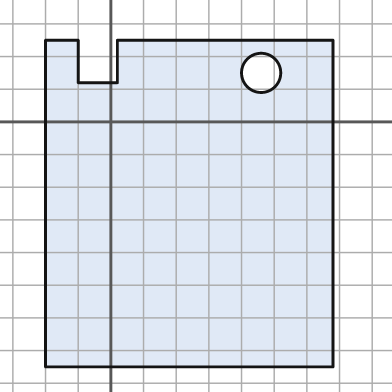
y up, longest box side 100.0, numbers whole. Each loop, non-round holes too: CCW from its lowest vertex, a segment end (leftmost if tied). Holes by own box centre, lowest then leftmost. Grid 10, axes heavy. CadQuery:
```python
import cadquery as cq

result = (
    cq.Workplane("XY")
    .moveTo(-20.0, -75.0)
    .lineTo(68.0, -75.0)
    .lineTo(68.0, 25.0)
    .lineTo(2.0, 25.0)
    .lineTo(2.0, 12.0)
    .lineTo(-10.0, 12.0)
    .lineTo(-10.0, 25.0)
    .lineTo(-20.0, 25.0)
    .close()
    .moveTo(46.0, 15.0)
    .circle(6.0)
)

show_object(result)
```